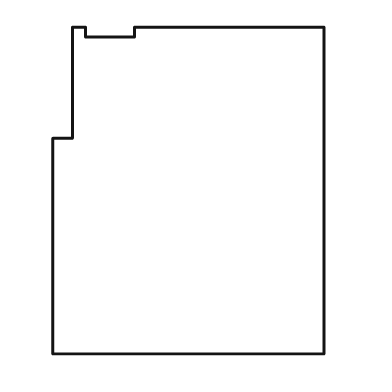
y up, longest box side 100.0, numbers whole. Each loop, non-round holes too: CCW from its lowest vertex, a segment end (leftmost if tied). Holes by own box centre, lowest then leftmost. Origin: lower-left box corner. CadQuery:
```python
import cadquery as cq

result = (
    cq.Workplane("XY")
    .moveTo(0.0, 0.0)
    .lineTo(83.0, 0.0)
    .lineTo(83.0, 100.0)
    .lineTo(25.0, 100.0)
    .lineTo(25.0, 97.0)
    .lineTo(10.0, 97.0)
    .lineTo(10.0, 100.0)
    .lineTo(6.0, 100.0)
    .lineTo(6.0, 66.0)
    .lineTo(0.0, 66.0)
    .close()
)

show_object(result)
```